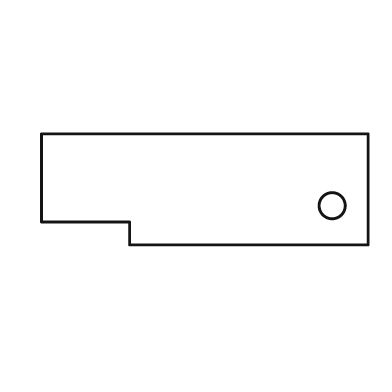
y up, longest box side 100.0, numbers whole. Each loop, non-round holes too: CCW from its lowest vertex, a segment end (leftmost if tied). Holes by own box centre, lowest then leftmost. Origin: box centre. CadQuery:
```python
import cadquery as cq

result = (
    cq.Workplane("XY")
    .moveTo(-23.0, -17.0)
    .lineTo(50.0, -17.0)
    .lineTo(50.0, 17.0)
    .lineTo(-50.0, 17.0)
    .lineTo(-50.0, -10.0)
    .lineTo(-23.0, -10.0)
    .close()
    .moveTo(39.0, -5.0)
    .circle(4.0)
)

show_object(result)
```